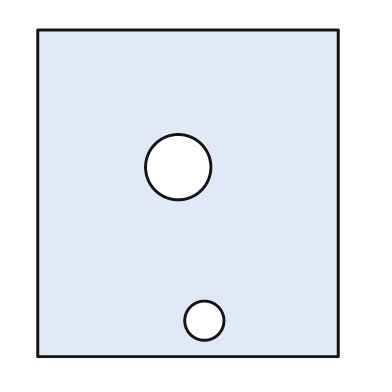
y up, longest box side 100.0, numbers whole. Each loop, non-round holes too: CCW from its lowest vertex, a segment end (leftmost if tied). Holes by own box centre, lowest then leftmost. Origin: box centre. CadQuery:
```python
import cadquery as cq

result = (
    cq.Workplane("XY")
    .moveTo(-46.0, -50.0)
    .lineTo(46.0, -50.0)
    .lineTo(46.0, 50.0)
    .lineTo(-46.0, 50.0)
    .close()
    .moveTo(5.0, -39.0)
    .circle(6.0)
    .moveTo(-3.0, 8.0)
    .circle(10.0)
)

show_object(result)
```